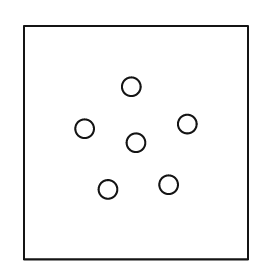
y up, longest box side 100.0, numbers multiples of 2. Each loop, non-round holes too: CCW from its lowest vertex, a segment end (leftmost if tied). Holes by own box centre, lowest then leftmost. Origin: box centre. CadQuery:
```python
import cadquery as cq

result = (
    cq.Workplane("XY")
    .moveTo(-48.0, -50.0)
    .lineTo(48.0, -50.0)
    .lineTo(48.0, 50.0)
    .lineTo(-48.0, 50.0)
    .close()
    .moveTo(-12.0, -20.0)
    .circle(4.0)
    .moveTo(14.0, -18.0)
    .circle(4.0)
    .moveTo(0.0, 0.0)
    .circle(4.0)
    .moveTo(-22.0, 6.0)
    .circle(4.0)
    .moveTo(22.0, 8.0)
    .circle(4.0)
    .moveTo(-2.0, 24.0)
    .circle(4.0)
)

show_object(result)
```